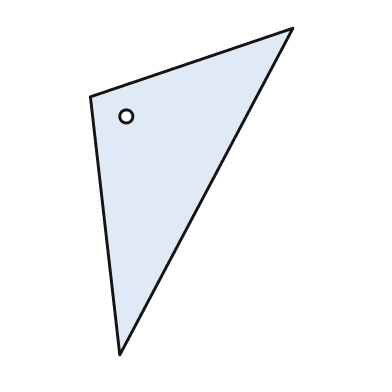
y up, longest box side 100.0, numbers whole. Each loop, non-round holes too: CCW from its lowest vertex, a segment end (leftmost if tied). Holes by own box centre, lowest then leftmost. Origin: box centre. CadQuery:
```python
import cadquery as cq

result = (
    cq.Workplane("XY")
    .moveTo(-22.0, -50.0)
    .lineTo(31.0, 50.0)
    .lineTo(-31.0, 29.0)
    .close()
    .moveTo(-20.0, 23.0)
    .circle(2.0)
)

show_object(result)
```